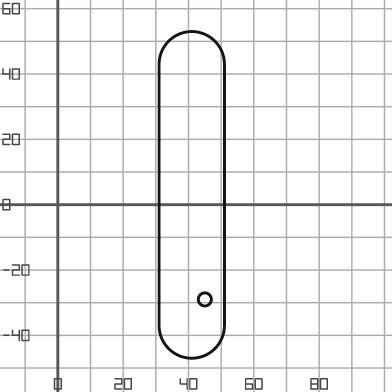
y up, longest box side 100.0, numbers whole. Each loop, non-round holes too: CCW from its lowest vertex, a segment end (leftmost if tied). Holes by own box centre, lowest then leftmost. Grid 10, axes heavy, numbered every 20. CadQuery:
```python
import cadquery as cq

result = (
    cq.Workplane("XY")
    .moveTo(31.0, -37.0)
    .threePointArc((41.0, -47.0), (51.0, -37.0))
    .lineTo(51.0, 43.0)
    .threePointArc((41.0, 53.0), (31.0, 43.0))
    .close()
    .moveTo(45.0, -29.0)
    .circle(2.0)
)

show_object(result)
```